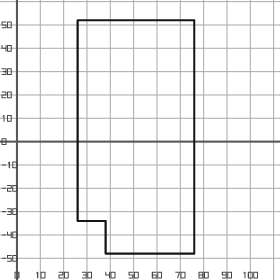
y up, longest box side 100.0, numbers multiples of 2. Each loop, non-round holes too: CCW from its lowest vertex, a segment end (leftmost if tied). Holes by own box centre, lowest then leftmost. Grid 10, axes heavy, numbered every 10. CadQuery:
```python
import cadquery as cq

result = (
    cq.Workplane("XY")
    .moveTo(38.0, -48.0)
    .lineTo(76.0, -48.0)
    .lineTo(76.0, 52.0)
    .lineTo(26.0, 52.0)
    .lineTo(26.0, -34.0)
    .lineTo(38.0, -34.0)
    .close()
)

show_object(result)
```